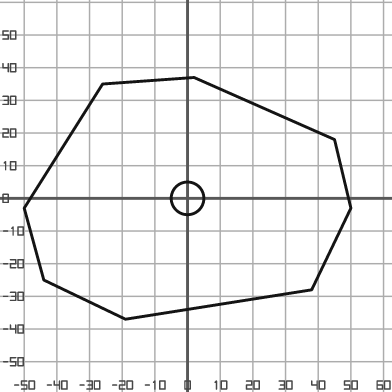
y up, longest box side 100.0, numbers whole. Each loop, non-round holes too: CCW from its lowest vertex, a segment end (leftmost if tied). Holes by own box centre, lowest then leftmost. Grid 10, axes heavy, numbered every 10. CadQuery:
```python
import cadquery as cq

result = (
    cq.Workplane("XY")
    .moveTo(-19.0, -37.0)
    .lineTo(38.0, -28.0)
    .lineTo(50.0, -3.0)
    .lineTo(45.0, 18.0)
    .lineTo(2.0, 37.0)
    .lineTo(-26.0, 35.0)
    .lineTo(-50.0, -3.0)
    .lineTo(-44.0, -25.0)
    .close()
    .moveTo(0.0, 0.0)
    .circle(5.0)
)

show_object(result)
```